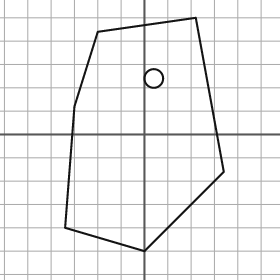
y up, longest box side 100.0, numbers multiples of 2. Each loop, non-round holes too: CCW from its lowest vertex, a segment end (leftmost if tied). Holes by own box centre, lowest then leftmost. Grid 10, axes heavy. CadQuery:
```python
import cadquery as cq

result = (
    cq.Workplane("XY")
    .moveTo(0.0, -50.0)
    .lineTo(34.0, -16.0)
    .lineTo(22.0, 50.0)
    .lineTo(-20.0, 44.0)
    .lineTo(-30.0, 12.0)
    .lineTo(-34.0, -40.0)
    .close()
    .moveTo(4.0, 24.0)
    .circle(4.0)
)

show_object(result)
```